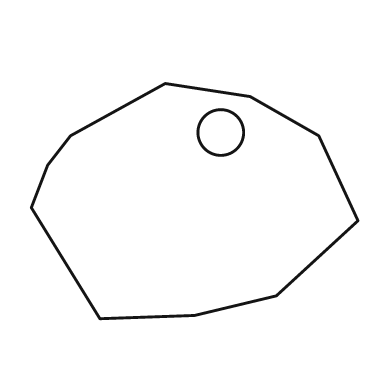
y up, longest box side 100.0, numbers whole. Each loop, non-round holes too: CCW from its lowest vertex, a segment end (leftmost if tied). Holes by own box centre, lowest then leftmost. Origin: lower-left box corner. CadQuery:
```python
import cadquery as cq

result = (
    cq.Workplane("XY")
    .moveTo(21.0, 0.0)
    .lineTo(50.0, 1.0)
    .lineTo(75.0, 7.0)
    .lineTo(100.0, 30.0)
    .lineTo(88.0, 56.0)
    .lineTo(67.0, 68.0)
    .lineTo(41.0, 72.0)
    .lineTo(12.0, 56.0)
    .lineTo(5.0, 47.0)
    .lineTo(0.0, 34.0)
    .close()
    .moveTo(58.0, 57.0)
    .circle(7.0)
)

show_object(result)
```